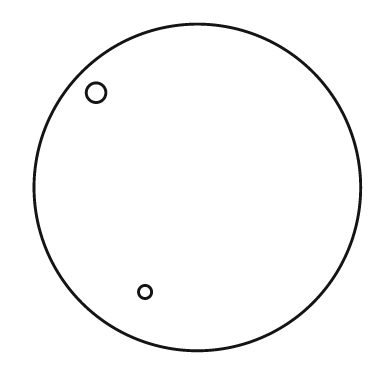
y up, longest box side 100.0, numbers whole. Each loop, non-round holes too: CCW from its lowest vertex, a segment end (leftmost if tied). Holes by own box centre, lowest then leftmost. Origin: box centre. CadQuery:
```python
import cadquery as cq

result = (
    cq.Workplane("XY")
    .moveTo(0.0, 0.0)
    .circle(50.0)
    .moveTo(-16.0, -32.0)
    .circle(2.0)
    .moveTo(-31.0, 29.0)
    .circle(3.0)
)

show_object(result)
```